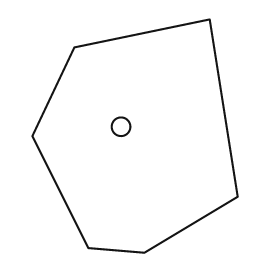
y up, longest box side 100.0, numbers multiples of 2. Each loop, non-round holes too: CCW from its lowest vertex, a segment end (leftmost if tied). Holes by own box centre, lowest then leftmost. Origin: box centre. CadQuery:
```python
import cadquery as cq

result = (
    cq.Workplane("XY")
    .moveTo(4.0, -50.0)
    .lineTo(44.0, -26.0)
    .lineTo(32.0, 50.0)
    .lineTo(-26.0, 38.0)
    .lineTo(-44.0, 0.0)
    .lineTo(-20.0, -48.0)
    .close()
    .moveTo(-6.0, 4.0)
    .circle(4.0)
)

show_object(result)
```